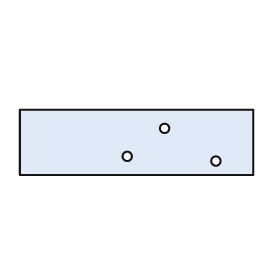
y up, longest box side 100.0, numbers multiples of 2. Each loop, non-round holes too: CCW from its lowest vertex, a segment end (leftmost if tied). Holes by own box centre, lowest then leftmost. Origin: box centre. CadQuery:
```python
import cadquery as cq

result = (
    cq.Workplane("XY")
    .moveTo(-50.0, -14.0)
    .lineTo(50.0, -14.0)
    .lineTo(50.0, 14.0)
    .lineTo(-50.0, 14.0)
    .close()
    .moveTo(34.0, -8.0)
    .circle(2.0)
    .moveTo(-4.0, -6.0)
    .circle(2.0)
    .moveTo(12.0, 6.0)
    .circle(2.0)
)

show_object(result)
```